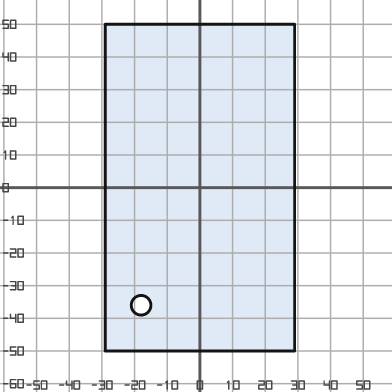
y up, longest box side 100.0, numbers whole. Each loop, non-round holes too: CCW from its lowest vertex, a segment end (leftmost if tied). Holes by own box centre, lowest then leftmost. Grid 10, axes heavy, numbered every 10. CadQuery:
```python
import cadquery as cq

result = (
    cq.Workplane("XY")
    .moveTo(-29.0, -50.0)
    .lineTo(29.0, -50.0)
    .lineTo(29.0, 50.0)
    .lineTo(-29.0, 50.0)
    .close()
    .moveTo(-18.0, -36.0)
    .circle(3.0)
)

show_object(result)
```